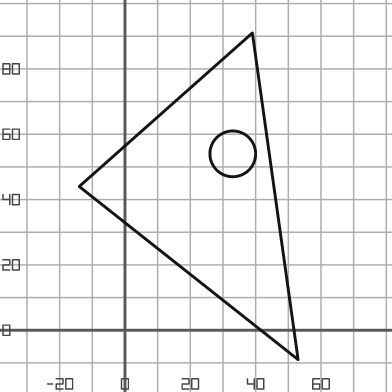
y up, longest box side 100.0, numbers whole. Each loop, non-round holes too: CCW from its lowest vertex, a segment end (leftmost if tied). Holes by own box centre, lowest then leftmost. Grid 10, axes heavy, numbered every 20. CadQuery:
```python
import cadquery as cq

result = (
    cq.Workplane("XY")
    .moveTo(53.0, -9.0)
    .lineTo(39.0, 91.0)
    .lineTo(-14.0, 44.0)
    .close()
    .moveTo(33.0, 54.0)
    .circle(7.0)
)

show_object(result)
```